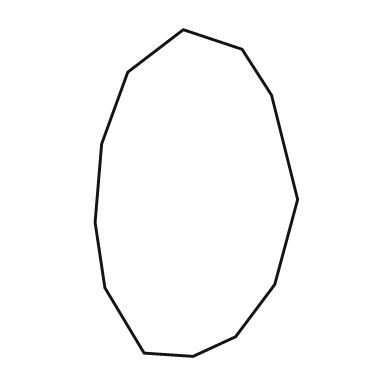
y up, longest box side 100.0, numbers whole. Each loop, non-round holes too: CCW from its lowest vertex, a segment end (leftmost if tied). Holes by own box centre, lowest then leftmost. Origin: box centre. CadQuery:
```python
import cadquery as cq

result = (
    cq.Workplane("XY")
    .moveTo(-1.0, -50.0)
    .lineTo(12.0, -44.0)
    .lineTo(24.0, -28.0)
    .lineTo(31.0, -2.0)
    .lineTo(23.0, 30.0)
    .lineTo(14.0, 44.0)
    .lineTo(-4.0, 50.0)
    .lineTo(-21.0, 37.0)
    .lineTo(-29.0, 15.0)
    .lineTo(-31.0, -9.0)
    .lineTo(-28.0, -29.0)
    .lineTo(-16.0, -49.0)
    .close()
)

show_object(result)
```